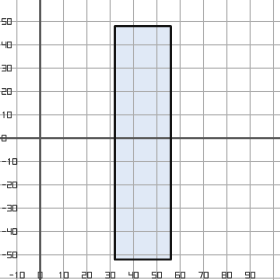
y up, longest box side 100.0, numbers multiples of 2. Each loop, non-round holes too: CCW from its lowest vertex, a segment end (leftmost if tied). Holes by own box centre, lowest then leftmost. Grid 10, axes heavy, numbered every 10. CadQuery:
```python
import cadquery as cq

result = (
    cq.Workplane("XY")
    .moveTo(32.0, -52.0)
    .lineTo(56.0, -52.0)
    .lineTo(56.0, 48.0)
    .lineTo(32.0, 48.0)
    .close()
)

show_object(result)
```